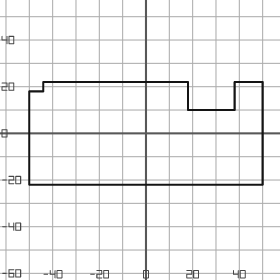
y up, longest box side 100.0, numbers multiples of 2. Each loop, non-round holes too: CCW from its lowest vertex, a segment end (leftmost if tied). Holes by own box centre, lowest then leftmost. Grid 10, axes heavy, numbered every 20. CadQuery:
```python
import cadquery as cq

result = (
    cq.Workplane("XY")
    .moveTo(-50.0, -22.0)
    .lineTo(50.0, -22.0)
    .lineTo(50.0, 22.0)
    .lineTo(38.0, 22.0)
    .lineTo(38.0, 10.0)
    .lineTo(18.0, 10.0)
    .lineTo(18.0, 22.0)
    .lineTo(-44.0, 22.0)
    .lineTo(-44.0, 18.0)
    .lineTo(-50.0, 18.0)
    .close()
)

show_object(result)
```